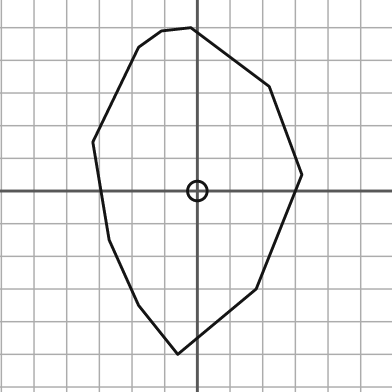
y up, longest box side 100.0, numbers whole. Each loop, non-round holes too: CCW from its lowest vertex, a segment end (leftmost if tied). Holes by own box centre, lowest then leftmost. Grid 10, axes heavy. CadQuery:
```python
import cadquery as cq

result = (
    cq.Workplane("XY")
    .moveTo(-6.0, -50.0)
    .lineTo(18.0, -30.0)
    .lineTo(32.0, 5.0)
    .lineTo(22.0, 32.0)
    .lineTo(-2.0, 50.0)
    .lineTo(-11.0, 49.0)
    .lineTo(-18.0, 44.0)
    .lineTo(-32.0, 15.0)
    .lineTo(-27.0, -15.0)
    .lineTo(-18.0, -35.0)
    .close()
    .moveTo(0.0, 0.0)
    .circle(3.0)
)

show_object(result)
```